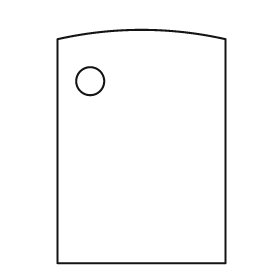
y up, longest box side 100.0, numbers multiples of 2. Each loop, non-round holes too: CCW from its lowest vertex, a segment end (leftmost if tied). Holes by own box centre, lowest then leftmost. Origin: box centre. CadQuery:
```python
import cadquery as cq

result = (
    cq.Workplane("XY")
    .moveTo(-36.0, -50.0)
    .lineTo(36.0, -50.0)
    .lineTo(36.0, 46.0)
    .threePointArc((0.0, 50.0), (-36.0, 46.0))
    .close()
    .moveTo(-22.0, 28.0)
    .circle(6.0)
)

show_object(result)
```